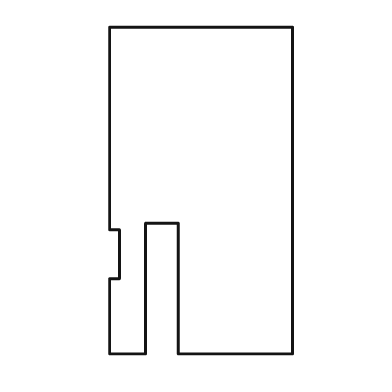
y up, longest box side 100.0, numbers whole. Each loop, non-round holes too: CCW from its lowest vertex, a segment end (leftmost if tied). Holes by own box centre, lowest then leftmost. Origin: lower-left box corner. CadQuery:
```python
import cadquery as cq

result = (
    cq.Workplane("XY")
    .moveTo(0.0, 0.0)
    .lineTo(11.0, 0.0)
    .lineTo(11.0, 40.0)
    .lineTo(21.0, 40.0)
    .lineTo(21.0, 0.0)
    .lineTo(56.0, 0.0)
    .lineTo(56.0, 100.0)
    .lineTo(0.0, 100.0)
    .lineTo(0.0, 38.0)
    .lineTo(3.0, 38.0)
    .lineTo(3.0, 23.0)
    .lineTo(0.0, 23.0)
    .close()
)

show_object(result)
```